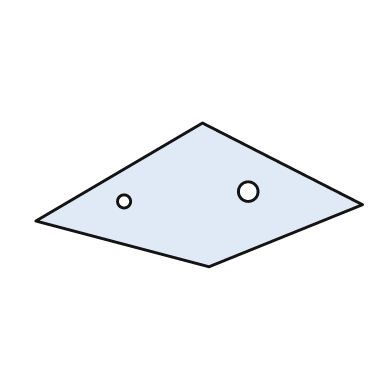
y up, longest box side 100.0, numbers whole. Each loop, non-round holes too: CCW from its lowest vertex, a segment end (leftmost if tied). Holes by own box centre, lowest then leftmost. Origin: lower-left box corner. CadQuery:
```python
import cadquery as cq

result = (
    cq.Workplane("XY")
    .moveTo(53.0, 0.0)
    .lineTo(100.0, 19.0)
    .lineTo(51.0, 44.0)
    .lineTo(0.0, 14.0)
    .close()
    .moveTo(27.0, 20.0)
    .circle(2.0)
    .moveTo(65.0, 23.0)
    .circle(3.0)
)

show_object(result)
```